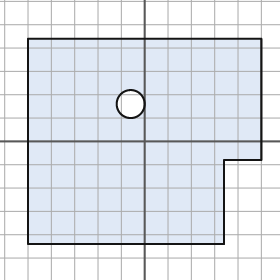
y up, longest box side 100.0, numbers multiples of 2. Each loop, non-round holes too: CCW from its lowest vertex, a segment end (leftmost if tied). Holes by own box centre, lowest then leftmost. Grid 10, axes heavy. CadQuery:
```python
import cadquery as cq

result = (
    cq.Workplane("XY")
    .moveTo(-50.0, -44.0)
    .lineTo(34.0, -44.0)
    .lineTo(34.0, -8.0)
    .lineTo(50.0, -8.0)
    .lineTo(50.0, 44.0)
    .lineTo(-50.0, 44.0)
    .close()
    .moveTo(-6.0, 16.0)
    .circle(6.0)
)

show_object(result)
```